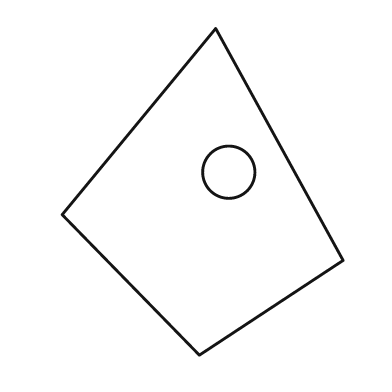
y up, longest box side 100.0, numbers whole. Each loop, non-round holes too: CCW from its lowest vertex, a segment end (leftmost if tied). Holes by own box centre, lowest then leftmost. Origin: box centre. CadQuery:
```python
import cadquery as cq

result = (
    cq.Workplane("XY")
    .moveTo(-1.0, -50.0)
    .lineTo(43.0, -21.0)
    .lineTo(4.0, 50.0)
    .lineTo(-43.0, -7.0)
    .close()
    .moveTo(8.0, 6.0)
    .circle(8.0)
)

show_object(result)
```